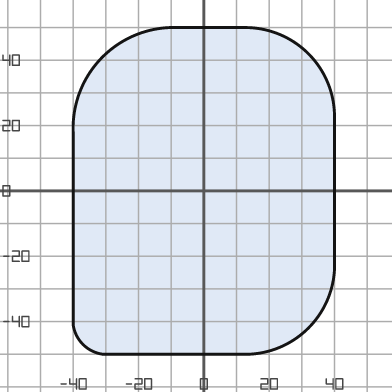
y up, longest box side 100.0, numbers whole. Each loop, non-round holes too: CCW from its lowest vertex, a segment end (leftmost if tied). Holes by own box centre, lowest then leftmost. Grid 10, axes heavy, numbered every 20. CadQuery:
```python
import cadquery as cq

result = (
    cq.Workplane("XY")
    .moveTo(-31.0, -50.0)
    .lineTo(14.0, -50.0)
    .threePointArc((32.0, -42.0), (40.0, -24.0))
    .lineTo(40.0, 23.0)
    .threePointArc((32.0, 42.0), (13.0, 50.0))
    .lineTo(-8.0, 50.0)
    .threePointArc((-31.0, 41.0), (-40.0, 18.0))
    .lineTo(-40.0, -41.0)
    .threePointArc((-37.0, -47.0), (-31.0, -50.0))
    .close()
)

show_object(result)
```